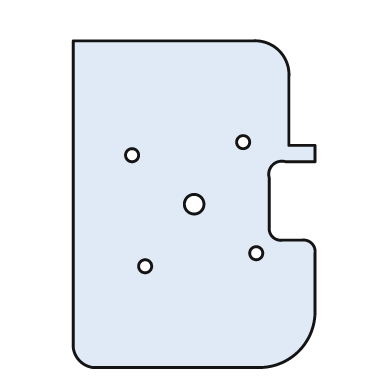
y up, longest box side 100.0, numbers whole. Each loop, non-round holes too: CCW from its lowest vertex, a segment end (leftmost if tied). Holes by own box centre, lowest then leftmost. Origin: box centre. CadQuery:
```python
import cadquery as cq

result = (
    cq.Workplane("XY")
    .moveTo(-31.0, -50.0)
    .lineTo(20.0, -50.0)
    .threePointArc((32.0, -45.0), (37.0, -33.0))
    .lineTo(37.0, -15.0)
    .threePointArc((36.0, -12.0), (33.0, -11.0))
    .lineTo(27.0, -11.0)
    .threePointArc((24.0, -10.0), (23.0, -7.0))
    .lineTo(23.0, 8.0)
    .threePointArc((24.0, 12.0), (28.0, 13.0))
    .lineTo(37.0, 13.0)
    .lineTo(37.0, 18.0)
    .lineTo(29.0, 18.0)
    .lineTo(29.0, 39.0)
    .threePointArc((26.0, 47.0), (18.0, 50.0))
    .lineTo(-37.0, 50.0)
    .lineTo(-37.0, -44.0)
    .threePointArc((-35.0, -48.0), (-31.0, -50.0))
    .close()
    .moveTo(-15.0, -19.0)
    .circle(2.0)
    .moveTo(19.0, -15.0)
    .circle(2.0)
    .moveTo(0.0, 0.0)
    .circle(3.0)
    .moveTo(-19.0, 15.0)
    .circle(2.0)
    .moveTo(15.0, 19.0)
    .circle(2.0)
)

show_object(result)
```